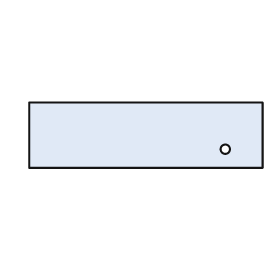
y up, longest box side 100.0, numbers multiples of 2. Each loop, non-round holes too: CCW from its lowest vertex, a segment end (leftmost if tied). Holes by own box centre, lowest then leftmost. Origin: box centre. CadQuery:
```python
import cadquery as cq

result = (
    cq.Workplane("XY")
    .moveTo(-50.0, -14.0)
    .lineTo(50.0, -14.0)
    .lineTo(50.0, 14.0)
    .lineTo(-50.0, 14.0)
    .close()
    .moveTo(34.0, -6.0)
    .circle(2.0)
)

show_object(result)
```